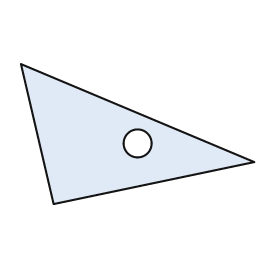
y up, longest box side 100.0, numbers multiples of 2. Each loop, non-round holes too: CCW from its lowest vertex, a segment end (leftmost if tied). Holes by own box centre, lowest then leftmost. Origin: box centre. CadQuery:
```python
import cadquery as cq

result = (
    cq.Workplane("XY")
    .moveTo(-36.0, -30.0)
    .lineTo(50.0, -12.0)
    .lineTo(-50.0, 30.0)
    .close()
    .moveTo(0.0, -4.0)
    .circle(6.0)
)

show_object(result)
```